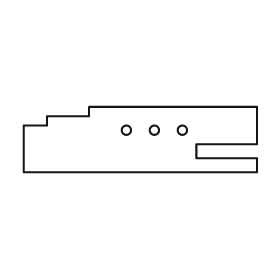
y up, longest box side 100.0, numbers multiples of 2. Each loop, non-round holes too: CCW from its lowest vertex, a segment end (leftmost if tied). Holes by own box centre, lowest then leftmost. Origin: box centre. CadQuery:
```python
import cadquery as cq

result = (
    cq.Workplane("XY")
    .moveTo(-50.0, -14.0)
    .lineTo(50.0, -14.0)
    .lineTo(50.0, -8.0)
    .lineTo(24.0, -8.0)
    .lineTo(24.0, -2.0)
    .lineTo(50.0, -2.0)
    .lineTo(50.0, 14.0)
    .lineTo(-22.0, 14.0)
    .lineTo(-22.0, 10.0)
    .lineTo(-40.0, 10.0)
    .lineTo(-40.0, 6.0)
    .lineTo(-50.0, 6.0)
    .close()
    .moveTo(-6.0, 4.0)
    .circle(2.0)
    .moveTo(6.0, 4.0)
    .circle(2.0)
    .moveTo(18.0, 4.0)
    .circle(2.0)
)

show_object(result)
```